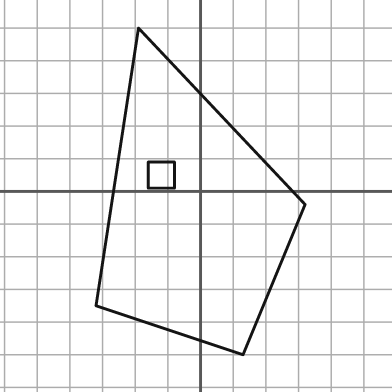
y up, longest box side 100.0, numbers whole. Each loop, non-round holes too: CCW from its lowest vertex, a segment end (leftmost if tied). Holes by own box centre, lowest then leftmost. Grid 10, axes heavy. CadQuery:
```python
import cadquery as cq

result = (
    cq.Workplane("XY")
    .moveTo(13.0, -50.0)
    .lineTo(32.0, -4.0)
    .lineTo(-19.0, 50.0)
    .lineTo(-32.0, -35.0)
    .close()
    .moveTo(-16.0, 1.0)
    .lineTo(-8.0, 1.0)
    .lineTo(-8.0, 9.0)
    .lineTo(-16.0, 9.0)
    .close()
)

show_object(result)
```